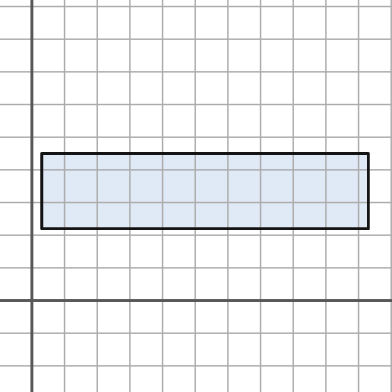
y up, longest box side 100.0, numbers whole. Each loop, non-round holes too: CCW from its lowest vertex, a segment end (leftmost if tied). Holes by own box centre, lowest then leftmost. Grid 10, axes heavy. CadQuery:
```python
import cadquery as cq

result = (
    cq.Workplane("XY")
    .moveTo(3.0, 22.0)
    .lineTo(103.0, 22.0)
    .lineTo(103.0, 45.0)
    .lineTo(3.0, 45.0)
    .close()
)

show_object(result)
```